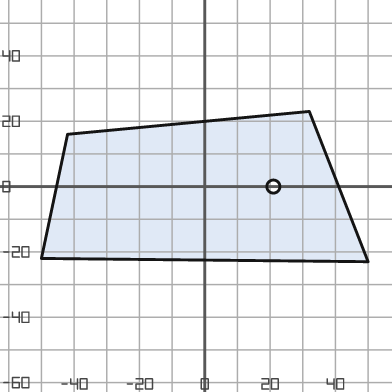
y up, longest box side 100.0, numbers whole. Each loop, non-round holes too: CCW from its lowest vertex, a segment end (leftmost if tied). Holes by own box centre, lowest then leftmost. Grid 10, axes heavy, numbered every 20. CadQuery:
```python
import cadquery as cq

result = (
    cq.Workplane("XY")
    .moveTo(50.0, -23.0)
    .lineTo(32.0, 23.0)
    .lineTo(-42.0, 16.0)
    .lineTo(-50.0, -22.0)
    .close()
    .moveTo(21.0, 0.0)
    .circle(2.0)
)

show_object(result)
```